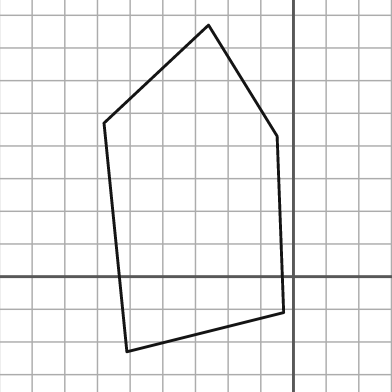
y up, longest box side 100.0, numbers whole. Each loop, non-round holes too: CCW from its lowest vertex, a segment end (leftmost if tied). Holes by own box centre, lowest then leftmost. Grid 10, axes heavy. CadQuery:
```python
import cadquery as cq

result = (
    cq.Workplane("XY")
    .moveTo(-51.0, -23.0)
    .lineTo(-3.0, -11.0)
    .lineTo(-5.0, 43.0)
    .lineTo(-26.0, 77.0)
    .lineTo(-58.0, 47.0)
    .close()
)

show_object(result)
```